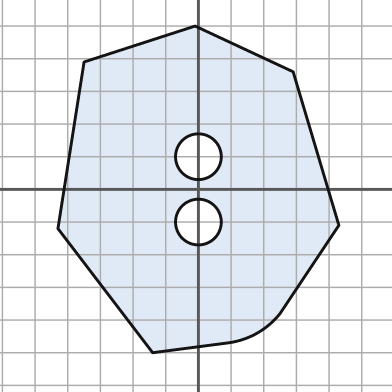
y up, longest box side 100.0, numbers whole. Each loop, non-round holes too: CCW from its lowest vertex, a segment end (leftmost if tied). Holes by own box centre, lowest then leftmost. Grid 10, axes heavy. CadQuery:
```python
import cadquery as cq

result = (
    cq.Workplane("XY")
    .moveTo(-14.0, -50.0)
    .lineTo(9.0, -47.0)
    .threePointArc((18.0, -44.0), (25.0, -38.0))
    .lineTo(43.0, -11.0)
    .lineTo(29.0, 36.0)
    .lineTo(-1.0, 50.0)
    .lineTo(-35.0, 39.0)
    .lineTo(-43.0, -12.0)
    .close()
    .moveTo(0.0, -10.0)
    .circle(7.0)
    .moveTo(0.0, 10.0)
    .circle(7.0)
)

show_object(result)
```